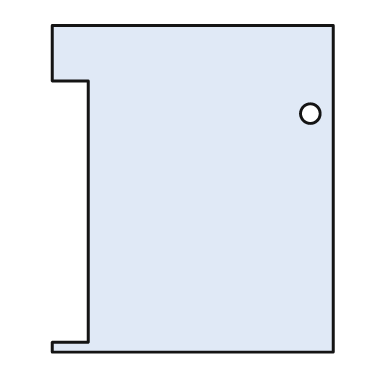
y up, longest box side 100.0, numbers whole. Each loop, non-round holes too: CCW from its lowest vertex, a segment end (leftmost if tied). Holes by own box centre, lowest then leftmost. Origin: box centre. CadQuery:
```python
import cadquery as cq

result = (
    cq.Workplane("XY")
    .moveTo(-43.0, -50.0)
    .lineTo(43.0, -50.0)
    .lineTo(43.0, 50.0)
    .lineTo(-43.0, 50.0)
    .lineTo(-43.0, 33.0)
    .lineTo(-32.0, 33.0)
    .lineTo(-32.0, -47.0)
    .lineTo(-43.0, -47.0)
    .close()
    .moveTo(36.0, 23.0)
    .circle(3.0)
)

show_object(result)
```